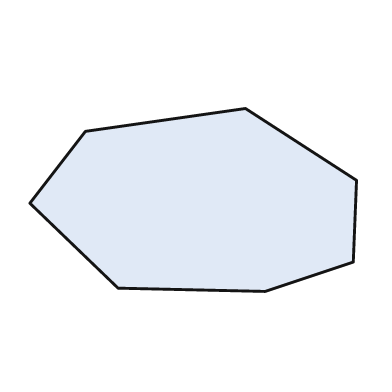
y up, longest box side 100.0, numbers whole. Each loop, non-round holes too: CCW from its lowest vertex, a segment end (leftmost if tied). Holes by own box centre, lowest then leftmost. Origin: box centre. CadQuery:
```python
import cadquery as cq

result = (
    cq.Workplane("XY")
    .moveTo(22.0, -28.0)
    .lineTo(49.0, -19.0)
    .lineTo(50.0, 6.0)
    .lineTo(16.0, 28.0)
    .lineTo(-33.0, 21.0)
    .lineTo(-50.0, -1.0)
    .lineTo(-23.0, -27.0)
    .close()
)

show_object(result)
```